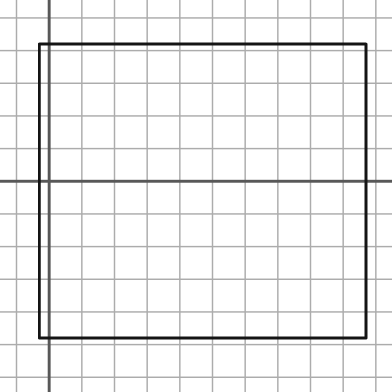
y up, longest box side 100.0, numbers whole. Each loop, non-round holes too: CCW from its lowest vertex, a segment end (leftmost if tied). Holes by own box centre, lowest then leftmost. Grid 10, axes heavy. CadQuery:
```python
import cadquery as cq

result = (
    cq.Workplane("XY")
    .moveTo(-3.0, -48.0)
    .lineTo(97.0, -48.0)
    .lineTo(97.0, 42.0)
    .lineTo(-3.0, 42.0)
    .close()
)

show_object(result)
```